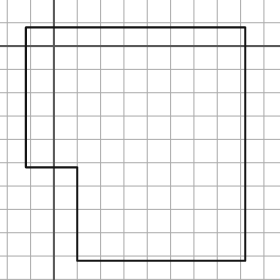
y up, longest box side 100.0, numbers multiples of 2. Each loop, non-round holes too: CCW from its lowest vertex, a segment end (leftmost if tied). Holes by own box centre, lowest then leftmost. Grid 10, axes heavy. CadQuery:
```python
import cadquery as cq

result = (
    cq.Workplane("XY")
    .moveTo(10.0, -92.0)
    .lineTo(82.0, -92.0)
    .lineTo(82.0, 8.0)
    .lineTo(-12.0, 8.0)
    .lineTo(-12.0, -52.0)
    .lineTo(10.0, -52.0)
    .close()
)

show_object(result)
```